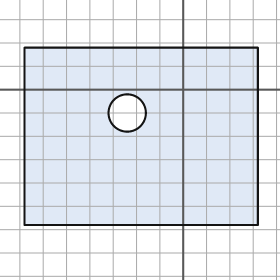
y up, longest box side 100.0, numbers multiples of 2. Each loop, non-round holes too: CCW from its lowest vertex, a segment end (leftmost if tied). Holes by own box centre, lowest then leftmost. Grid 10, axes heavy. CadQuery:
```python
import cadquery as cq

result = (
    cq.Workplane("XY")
    .moveTo(-68.0, -58.0)
    .lineTo(32.0, -58.0)
    .lineTo(32.0, 18.0)
    .lineTo(-68.0, 18.0)
    .close()
    .moveTo(-24.0, -10.0)
    .circle(8.0)
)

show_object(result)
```